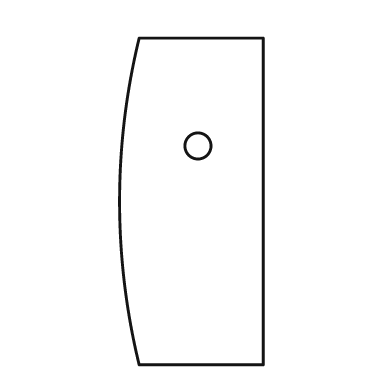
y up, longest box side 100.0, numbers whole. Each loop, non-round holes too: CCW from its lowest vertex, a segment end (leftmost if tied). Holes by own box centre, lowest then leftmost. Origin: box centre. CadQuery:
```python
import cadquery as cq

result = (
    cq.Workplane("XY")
    .moveTo(-16.0, -50.0)
    .lineTo(22.0, -50.0)
    .lineTo(22.0, 50.0)
    .lineTo(-16.0, 50.0)
    .threePointArc((-22.0, 0.0), (-16.0, -50.0))
    .close()
    .moveTo(2.0, 17.0)
    .circle(4.0)
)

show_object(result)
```